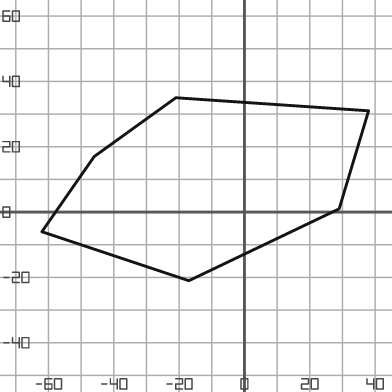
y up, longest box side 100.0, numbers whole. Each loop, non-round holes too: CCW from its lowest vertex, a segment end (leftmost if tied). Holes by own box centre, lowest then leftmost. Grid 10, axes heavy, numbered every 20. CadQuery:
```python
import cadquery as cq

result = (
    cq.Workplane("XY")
    .moveTo(-17.0, -21.0)
    .lineTo(29.0, 1.0)
    .lineTo(38.0, 31.0)
    .lineTo(-21.0, 35.0)
    .lineTo(-46.0, 17.0)
    .lineTo(-62.0, -6.0)
    .close()
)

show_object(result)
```